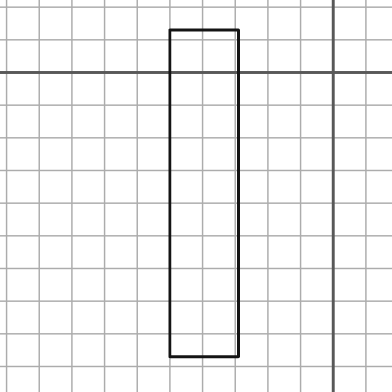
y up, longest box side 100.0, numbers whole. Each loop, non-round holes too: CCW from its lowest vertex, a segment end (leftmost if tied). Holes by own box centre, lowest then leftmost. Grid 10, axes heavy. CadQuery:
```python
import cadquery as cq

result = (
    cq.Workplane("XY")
    .moveTo(-50.0, -87.0)
    .lineTo(-29.0, -87.0)
    .lineTo(-29.0, 13.0)
    .lineTo(-50.0, 13.0)
    .close()
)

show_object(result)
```